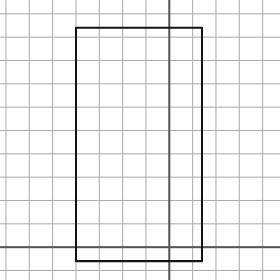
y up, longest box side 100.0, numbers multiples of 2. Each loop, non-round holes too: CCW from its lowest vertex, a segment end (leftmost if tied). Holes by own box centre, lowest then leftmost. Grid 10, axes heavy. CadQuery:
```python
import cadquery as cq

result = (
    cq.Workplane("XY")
    .moveTo(-40.0, -6.0)
    .lineTo(14.0, -6.0)
    .lineTo(14.0, 94.0)
    .lineTo(-40.0, 94.0)
    .close()
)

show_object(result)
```